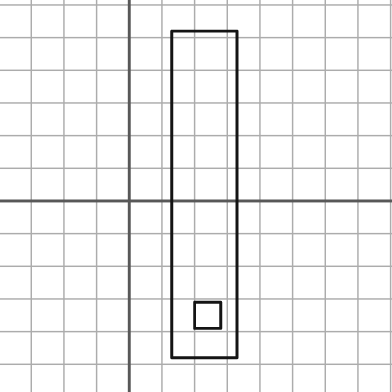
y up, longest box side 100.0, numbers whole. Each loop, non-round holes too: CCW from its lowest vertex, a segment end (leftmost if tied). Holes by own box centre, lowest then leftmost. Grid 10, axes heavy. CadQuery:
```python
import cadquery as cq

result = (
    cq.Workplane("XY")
    .moveTo(13.0, -48.0)
    .lineTo(33.0, -48.0)
    .lineTo(33.0, 52.0)
    .lineTo(13.0, 52.0)
    .close()
    .moveTo(20.0, -39.0)
    .lineTo(28.0, -39.0)
    .lineTo(28.0, -31.0)
    .lineTo(20.0, -31.0)
    .close()
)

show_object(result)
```